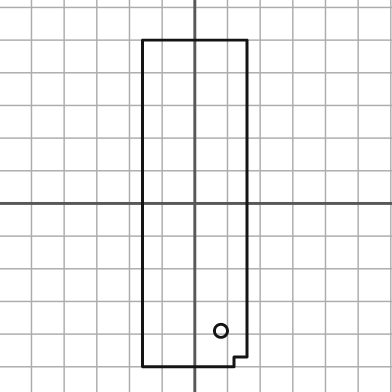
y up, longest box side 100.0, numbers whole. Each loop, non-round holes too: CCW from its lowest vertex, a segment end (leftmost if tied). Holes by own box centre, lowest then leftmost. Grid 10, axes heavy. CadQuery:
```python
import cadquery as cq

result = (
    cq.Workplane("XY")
    .moveTo(-16.0, -50.0)
    .lineTo(12.0, -50.0)
    .lineTo(12.0, -47.0)
    .lineTo(16.0, -47.0)
    .lineTo(16.0, 50.0)
    .lineTo(-16.0, 50.0)
    .close()
    .moveTo(8.0, -39.0)
    .circle(2.0)
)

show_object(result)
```